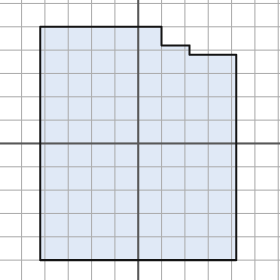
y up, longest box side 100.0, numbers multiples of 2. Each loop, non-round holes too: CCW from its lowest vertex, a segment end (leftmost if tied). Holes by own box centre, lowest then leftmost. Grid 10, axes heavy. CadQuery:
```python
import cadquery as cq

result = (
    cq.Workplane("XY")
    .moveTo(-42.0, -50.0)
    .lineTo(42.0, -50.0)
    .lineTo(42.0, 38.0)
    .lineTo(22.0, 38.0)
    .lineTo(22.0, 42.0)
    .lineTo(10.0, 42.0)
    .lineTo(10.0, 50.0)
    .lineTo(-42.0, 50.0)
    .close()
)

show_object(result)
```